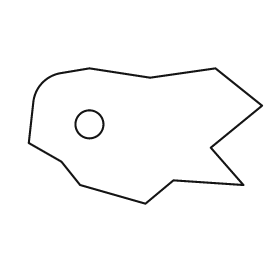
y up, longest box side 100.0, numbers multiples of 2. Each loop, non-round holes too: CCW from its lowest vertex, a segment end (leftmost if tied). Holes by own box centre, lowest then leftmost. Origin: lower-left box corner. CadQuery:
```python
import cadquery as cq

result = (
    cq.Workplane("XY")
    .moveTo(50.0, 0.0)
    .lineTo(62.0, 10.0)
    .lineTo(92.0, 8.0)
    .lineTo(78.0, 24.0)
    .lineTo(100.0, 42.0)
    .lineTo(80.0, 58.0)
    .lineTo(52.0, 54.0)
    .lineTo(26.0, 58.0)
    .lineTo(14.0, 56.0)
    .threePointArc((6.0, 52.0), (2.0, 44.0))
    .lineTo(0.0, 26.0)
    .lineTo(14.0, 18.0)
    .lineTo(22.0, 8.0)
    .close()
    .moveTo(26.0, 34.0)
    .circle(6.0)
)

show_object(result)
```